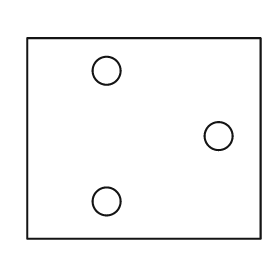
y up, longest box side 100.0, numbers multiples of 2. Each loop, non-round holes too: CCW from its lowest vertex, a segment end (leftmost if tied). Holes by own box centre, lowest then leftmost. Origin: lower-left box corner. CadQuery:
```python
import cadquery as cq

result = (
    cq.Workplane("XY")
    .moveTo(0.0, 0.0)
    .lineTo(100.0, 0.0)
    .lineTo(100.0, 86.0)
    .lineTo(0.0, 86.0)
    .close()
    .moveTo(34.0, 16.0)
    .circle(6.0)
    .moveTo(82.0, 44.0)
    .circle(6.0)
    .moveTo(34.0, 72.0)
    .circle(6.0)
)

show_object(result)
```